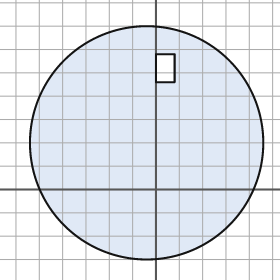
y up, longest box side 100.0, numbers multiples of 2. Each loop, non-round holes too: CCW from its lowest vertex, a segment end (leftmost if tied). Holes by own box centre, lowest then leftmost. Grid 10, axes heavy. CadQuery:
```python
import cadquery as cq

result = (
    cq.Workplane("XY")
    .moveTo(-4.0, 20.0)
    .circle(50.0)
    .moveTo(0.0, 46.0)
    .lineTo(8.0, 46.0)
    .lineTo(8.0, 58.0)
    .lineTo(0.0, 58.0)
    .close()
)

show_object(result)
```